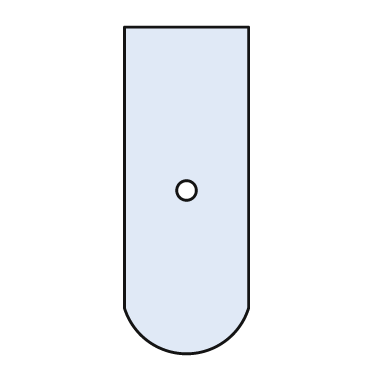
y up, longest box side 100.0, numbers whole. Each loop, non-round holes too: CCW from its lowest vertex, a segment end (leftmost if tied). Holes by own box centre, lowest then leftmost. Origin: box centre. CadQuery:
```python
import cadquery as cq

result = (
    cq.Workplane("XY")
    .moveTo(-19.0, -36.0)
    .threePointArc((0.0, -50.0), (19.0, -36.0))
    .lineTo(19.0, 50.0)
    .lineTo(-19.0, 50.0)
    .close()
    .moveTo(0.0, 0.0)
    .circle(3.0)
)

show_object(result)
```